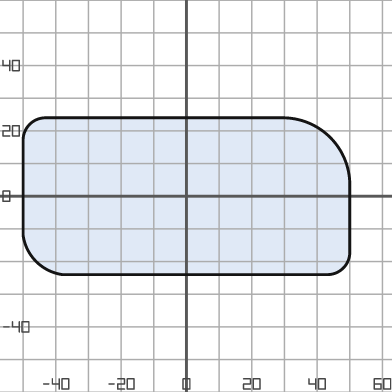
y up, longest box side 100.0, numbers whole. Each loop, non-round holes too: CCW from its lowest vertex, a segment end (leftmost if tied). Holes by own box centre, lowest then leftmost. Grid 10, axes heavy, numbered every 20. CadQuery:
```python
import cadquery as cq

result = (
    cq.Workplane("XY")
    .moveTo(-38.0, -24.0)
    .lineTo(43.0, -24.0)
    .threePointArc((48.0, -22.0), (50.0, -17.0))
    .lineTo(50.0, 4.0)
    .threePointArc((44.0, 18.0), (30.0, 24.0))
    .lineTo(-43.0, 24.0)
    .threePointArc((-48.0, 22.0), (-50.0, 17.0))
    .lineTo(-50.0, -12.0)
    .threePointArc((-46.0, -20.0), (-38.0, -24.0))
    .close()
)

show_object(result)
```